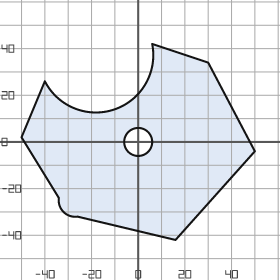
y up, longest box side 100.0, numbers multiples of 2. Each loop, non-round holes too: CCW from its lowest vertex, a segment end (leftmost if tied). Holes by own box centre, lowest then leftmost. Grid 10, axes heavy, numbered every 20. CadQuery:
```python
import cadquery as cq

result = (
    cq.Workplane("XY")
    .moveTo(16.0, -42.0)
    .lineTo(50.0, -4.0)
    .lineTo(30.0, 34.0)
    .lineTo(6.0, 42.0)
    .threePointArc((-10.0, 14.0), (-40.0, 26.0))
    .lineTo(-50.0, 2.0)
    .lineTo(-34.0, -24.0)
    .threePointArc((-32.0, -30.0), (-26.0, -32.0))
    .close()
    .moveTo(0.0, 0.0)
    .circle(6.0)
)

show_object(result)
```